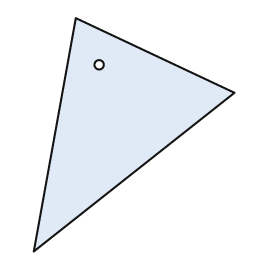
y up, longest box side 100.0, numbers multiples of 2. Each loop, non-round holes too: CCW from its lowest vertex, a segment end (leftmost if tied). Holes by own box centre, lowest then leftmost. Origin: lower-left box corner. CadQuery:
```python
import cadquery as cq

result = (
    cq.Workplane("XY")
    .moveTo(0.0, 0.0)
    .lineTo(86.0, 68.0)
    .lineTo(18.0, 100.0)
    .close()
    .moveTo(28.0, 80.0)
    .circle(2.0)
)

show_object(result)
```